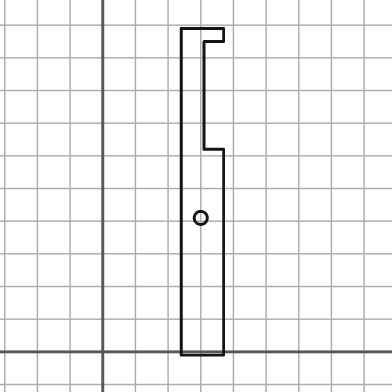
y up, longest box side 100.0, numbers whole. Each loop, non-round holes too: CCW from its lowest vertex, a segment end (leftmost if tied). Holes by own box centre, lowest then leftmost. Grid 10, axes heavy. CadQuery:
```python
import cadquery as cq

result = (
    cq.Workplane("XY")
    .moveTo(24.0, -1.0)
    .lineTo(37.0, -1.0)
    .lineTo(37.0, 62.0)
    .lineTo(31.0, 62.0)
    .lineTo(31.0, 95.0)
    .lineTo(37.0, 95.0)
    .lineTo(37.0, 99.0)
    .lineTo(24.0, 99.0)
    .close()
    .moveTo(30.0, 41.0)
    .circle(2.0)
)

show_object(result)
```